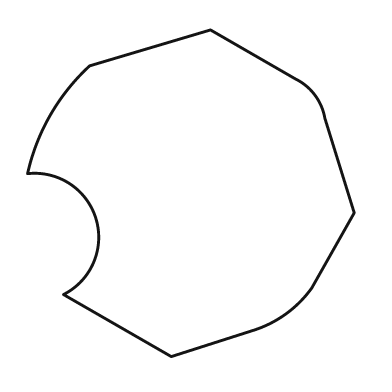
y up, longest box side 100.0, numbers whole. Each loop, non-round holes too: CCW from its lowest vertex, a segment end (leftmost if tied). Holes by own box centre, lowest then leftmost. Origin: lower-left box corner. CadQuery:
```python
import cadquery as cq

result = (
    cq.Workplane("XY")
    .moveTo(44.0, 0.0)
    .lineTo(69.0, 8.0)
    .threePointArc((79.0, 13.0), (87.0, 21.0))
    .lineTo(100.0, 44.0)
    .lineTo(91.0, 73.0)
    .threePointArc((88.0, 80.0), (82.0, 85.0))
    .lineTo(56.0, 100.0)
    .lineTo(19.0, 89.0)
    .threePointArc((7.0, 74.0), (0.0, 56.0))
    .threePointArc((21.0, 42.0), (11.0, 19.0))
    .close()
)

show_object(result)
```